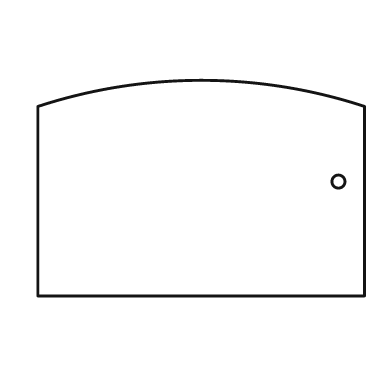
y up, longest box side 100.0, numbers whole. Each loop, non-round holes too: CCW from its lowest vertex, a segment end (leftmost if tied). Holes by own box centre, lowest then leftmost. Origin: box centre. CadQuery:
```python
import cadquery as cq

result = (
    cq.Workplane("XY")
    .moveTo(-50.0, -33.0)
    .lineTo(50.0, -33.0)
    .lineTo(50.0, 25.0)
    .threePointArc((0.0, 33.0), (-50.0, 25.0))
    .close()
    .moveTo(42.0, 2.0)
    .circle(2.0)
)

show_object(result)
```